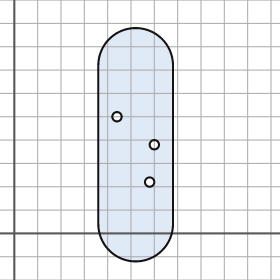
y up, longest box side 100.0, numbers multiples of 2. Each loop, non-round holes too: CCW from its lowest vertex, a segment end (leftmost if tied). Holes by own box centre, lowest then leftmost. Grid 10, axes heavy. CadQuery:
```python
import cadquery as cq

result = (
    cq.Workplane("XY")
    .moveTo(36.0, 4.0)
    .threePointArc((52.0, -12.0), (68.0, 4.0))
    .lineTo(68.0, 72.0)
    .threePointArc((52.0, 88.0), (36.0, 72.0))
    .close()
    .moveTo(58.0, 22.0)
    .circle(2.0)
    .moveTo(60.0, 38.0)
    .circle(2.0)
    .moveTo(44.0, 50.0)
    .circle(2.0)
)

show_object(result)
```